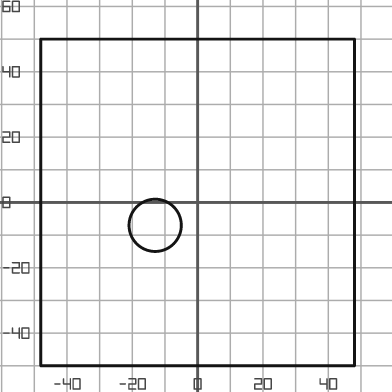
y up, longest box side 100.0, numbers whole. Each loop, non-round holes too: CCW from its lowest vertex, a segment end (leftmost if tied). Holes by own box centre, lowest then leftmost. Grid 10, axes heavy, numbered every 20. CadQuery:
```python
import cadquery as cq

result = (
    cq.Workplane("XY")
    .moveTo(-48.0, -50.0)
    .lineTo(48.0, -50.0)
    .lineTo(48.0, 50.0)
    .lineTo(-48.0, 50.0)
    .close()
    .moveTo(-13.0, -7.0)
    .circle(8.0)
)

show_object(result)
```